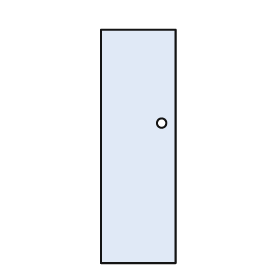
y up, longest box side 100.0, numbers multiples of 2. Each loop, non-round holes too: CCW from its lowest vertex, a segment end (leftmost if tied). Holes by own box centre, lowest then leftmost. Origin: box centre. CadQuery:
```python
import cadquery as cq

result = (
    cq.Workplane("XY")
    .moveTo(-16.0, -50.0)
    .lineTo(16.0, -50.0)
    .lineTo(16.0, 50.0)
    .lineTo(-16.0, 50.0)
    .close()
    .moveTo(10.0, 10.0)
    .circle(2.0)
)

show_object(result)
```